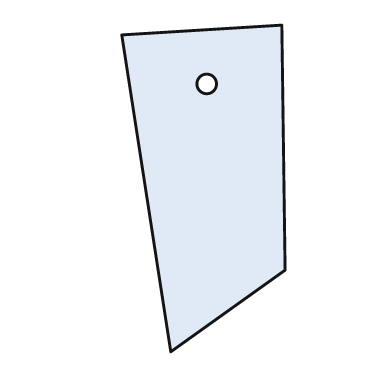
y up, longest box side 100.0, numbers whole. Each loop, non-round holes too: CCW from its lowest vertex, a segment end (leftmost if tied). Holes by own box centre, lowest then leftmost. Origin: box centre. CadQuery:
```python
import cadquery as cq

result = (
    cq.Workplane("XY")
    .moveTo(-10.0, -50.0)
    .lineTo(25.0, -25.0)
    .lineTo(24.0, 50.0)
    .lineTo(-25.0, 47.0)
    .close()
    .moveTo(1.0, 32.0)
    .circle(3.0)
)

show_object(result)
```